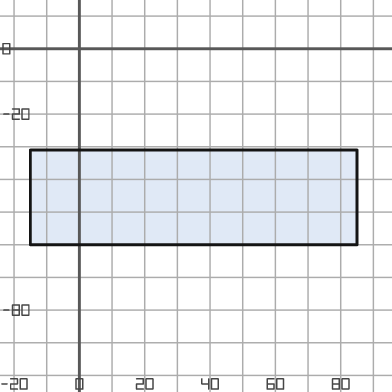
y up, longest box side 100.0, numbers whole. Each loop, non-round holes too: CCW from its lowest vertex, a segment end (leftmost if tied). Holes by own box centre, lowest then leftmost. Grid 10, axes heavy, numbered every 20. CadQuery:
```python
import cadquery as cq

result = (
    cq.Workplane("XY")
    .moveTo(-15.0, -60.0)
    .lineTo(85.0, -60.0)
    .lineTo(85.0, -31.0)
    .lineTo(-15.0, -31.0)
    .close()
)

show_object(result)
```